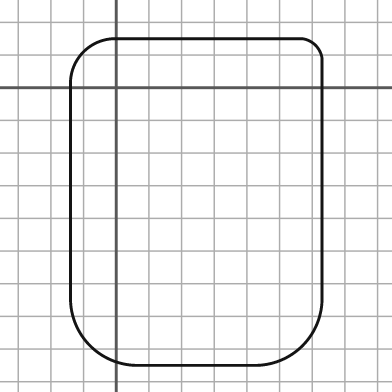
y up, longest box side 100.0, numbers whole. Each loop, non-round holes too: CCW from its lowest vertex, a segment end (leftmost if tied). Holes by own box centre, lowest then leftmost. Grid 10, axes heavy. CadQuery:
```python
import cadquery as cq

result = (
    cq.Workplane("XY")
    .moveTo(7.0, -85.0)
    .lineTo(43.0, -85.0)
    .threePointArc((57.0, -79.0), (63.0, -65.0))
    .lineTo(63.0, 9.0)
    .threePointArc((61.0, 13.0), (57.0, 15.0))
    .lineTo(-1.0, 15.0)
    .threePointArc((-10.0, 11.0), (-14.0, 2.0))
    .lineTo(-14.0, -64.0)
    .threePointArc((-8.0, -79.0), (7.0, -85.0))
    .close()
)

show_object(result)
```